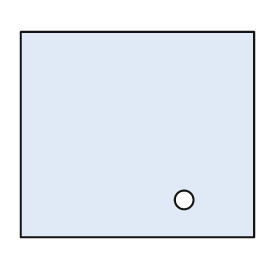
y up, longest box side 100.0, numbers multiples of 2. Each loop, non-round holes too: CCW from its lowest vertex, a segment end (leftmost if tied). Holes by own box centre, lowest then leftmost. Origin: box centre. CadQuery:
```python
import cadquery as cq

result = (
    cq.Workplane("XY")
    .moveTo(-50.0, -44.0)
    .lineTo(50.0, -44.0)
    .lineTo(50.0, 44.0)
    .lineTo(-50.0, 44.0)
    .close()
    .moveTo(20.0, -28.0)
    .circle(4.0)
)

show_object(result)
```